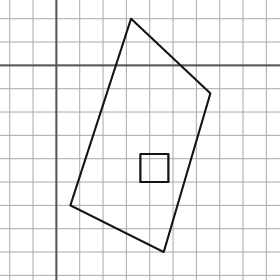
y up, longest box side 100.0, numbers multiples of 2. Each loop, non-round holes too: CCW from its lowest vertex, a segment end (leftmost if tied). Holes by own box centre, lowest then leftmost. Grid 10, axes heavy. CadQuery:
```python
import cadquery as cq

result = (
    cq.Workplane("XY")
    .moveTo(46.0, -80.0)
    .lineTo(66.0, -12.0)
    .lineTo(32.0, 20.0)
    .lineTo(6.0, -60.0)
    .close()
    .moveTo(36.0, -50.0)
    .lineTo(48.0, -50.0)
    .lineTo(48.0, -38.0)
    .lineTo(36.0, -38.0)
    .close()
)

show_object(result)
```